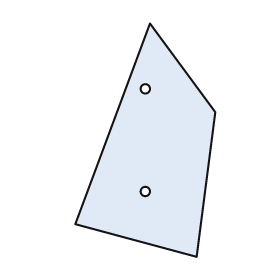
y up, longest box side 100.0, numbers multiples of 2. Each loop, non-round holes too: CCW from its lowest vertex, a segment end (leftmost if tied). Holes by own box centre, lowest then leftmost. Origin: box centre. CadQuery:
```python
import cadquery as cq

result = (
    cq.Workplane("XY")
    .moveTo(22.0, -50.0)
    .lineTo(30.0, 12.0)
    .lineTo(2.0, 50.0)
    .lineTo(-30.0, -36.0)
    .close()
    .moveTo(0.0, -22.0)
    .circle(2.0)
    .moveTo(0.0, 22.0)
    .circle(2.0)
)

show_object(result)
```